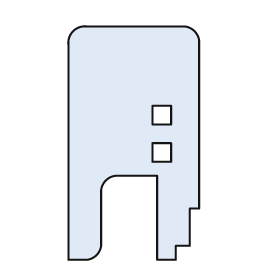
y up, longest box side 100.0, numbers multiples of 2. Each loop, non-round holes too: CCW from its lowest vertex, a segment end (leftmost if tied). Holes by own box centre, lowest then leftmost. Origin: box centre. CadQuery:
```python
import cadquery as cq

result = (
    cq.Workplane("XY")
    .moveTo(-28.0, -50.0)
    .lineTo(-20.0, -50.0)
    .threePointArc((-16.0, -48.0), (-14.0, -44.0))
    .lineTo(-14.0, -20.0)
    .threePointArc((-12.0, -16.0), (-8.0, -14.0))
    .lineTo(10.0, -14.0)
    .lineTo(10.0, -50.0)
    .lineTo(18.0, -50.0)
    .lineTo(18.0, -44.0)
    .lineTo(24.0, -44.0)
    .lineTo(24.0, -28.0)
    .lineTo(28.0, -28.0)
    .lineTo(28.0, 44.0)
    .threePointArc((26.0, 48.0), (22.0, 50.0))
    .lineTo(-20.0, 50.0)
    .threePointArc((-26.0, 48.0), (-28.0, 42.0))
    .close()
    .moveTo(8.0, -8.0)
    .lineTo(16.0, -8.0)
    .lineTo(16.0, 0.0)
    .lineTo(8.0, 0.0)
    .close()
    .moveTo(8.0, 8.0)
    .lineTo(16.0, 8.0)
    .lineTo(16.0, 16.0)
    .lineTo(8.0, 16.0)
    .close()
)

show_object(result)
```